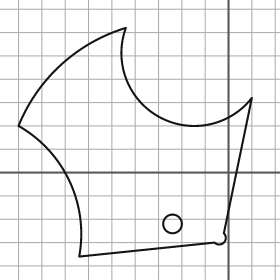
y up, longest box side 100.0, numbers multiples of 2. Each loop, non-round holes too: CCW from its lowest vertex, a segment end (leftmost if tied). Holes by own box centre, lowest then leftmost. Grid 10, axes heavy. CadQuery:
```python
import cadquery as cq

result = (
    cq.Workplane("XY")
    .moveTo(-64.0, -36.0)
    .lineTo(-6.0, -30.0)
    .threePointArc((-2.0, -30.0), (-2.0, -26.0))
    .lineTo(10.0, 32.0)
    .threePointArc((-30.0, 24.0), (-44.0, 62.0))
    .threePointArc((-72.0, 46.0), (-90.0, 20.0))
    .threePointArc((-68.0, -4.0), (-64.0, -36.0))
    .close()
    .moveTo(-24.0, -22.0)
    .circle(4.0)
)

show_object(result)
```